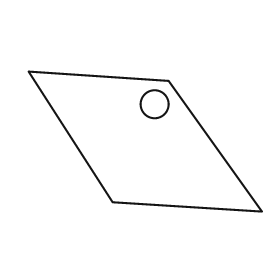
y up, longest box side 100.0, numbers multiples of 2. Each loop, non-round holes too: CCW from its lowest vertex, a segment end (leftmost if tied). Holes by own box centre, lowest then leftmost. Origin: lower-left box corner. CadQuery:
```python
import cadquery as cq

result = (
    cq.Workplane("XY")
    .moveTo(100.0, 0.0)
    .lineTo(60.0, 56.0)
    .lineTo(0.0, 60.0)
    .lineTo(36.0, 4.0)
    .close()
    .moveTo(54.0, 46.0)
    .circle(6.0)
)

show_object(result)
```